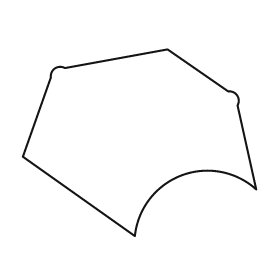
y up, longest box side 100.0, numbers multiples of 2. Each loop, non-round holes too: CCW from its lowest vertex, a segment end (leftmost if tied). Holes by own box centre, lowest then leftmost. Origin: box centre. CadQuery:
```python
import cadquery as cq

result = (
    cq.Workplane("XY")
    .moveTo(-2.0, -40.0)
    .threePointArc((18.0, -14.0), (50.0, -20.0))
    .lineTo(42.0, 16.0)
    .threePointArc((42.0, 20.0), (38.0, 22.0))
    .lineTo(12.0, 40.0)
    .lineTo(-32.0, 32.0)
    .threePointArc((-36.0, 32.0), (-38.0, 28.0))
    .lineTo(-50.0, -6.0)
    .close()
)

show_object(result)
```